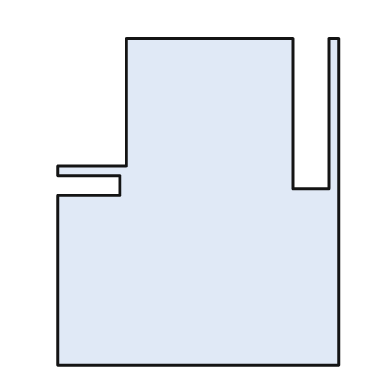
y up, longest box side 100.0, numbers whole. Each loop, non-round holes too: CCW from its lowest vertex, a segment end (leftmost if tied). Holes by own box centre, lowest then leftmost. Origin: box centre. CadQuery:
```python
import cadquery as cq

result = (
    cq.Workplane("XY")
    .moveTo(-43.0, -50.0)
    .lineTo(43.0, -50.0)
    .lineTo(43.0, 50.0)
    .lineTo(40.0, 50.0)
    .lineTo(40.0, 4.0)
    .lineTo(29.0, 4.0)
    .lineTo(29.0, 50.0)
    .lineTo(-22.0, 50.0)
    .lineTo(-22.0, 11.0)
    .lineTo(-43.0, 11.0)
    .lineTo(-43.0, 8.0)
    .lineTo(-24.0, 8.0)
    .lineTo(-24.0, 2.0)
    .lineTo(-43.0, 2.0)
    .close()
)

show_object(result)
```